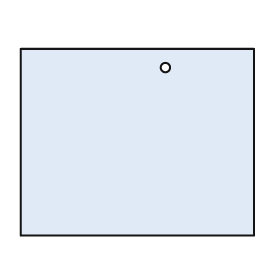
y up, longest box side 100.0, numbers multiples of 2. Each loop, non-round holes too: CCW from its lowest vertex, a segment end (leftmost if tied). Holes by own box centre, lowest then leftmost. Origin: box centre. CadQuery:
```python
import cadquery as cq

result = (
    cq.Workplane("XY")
    .moveTo(-50.0, -40.0)
    .lineTo(50.0, -40.0)
    .lineTo(50.0, 40.0)
    .lineTo(-50.0, 40.0)
    .close()
    .moveTo(12.0, 32.0)
    .circle(2.0)
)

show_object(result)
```